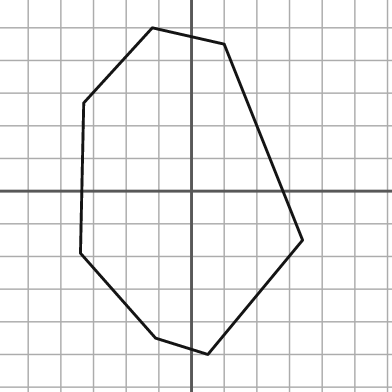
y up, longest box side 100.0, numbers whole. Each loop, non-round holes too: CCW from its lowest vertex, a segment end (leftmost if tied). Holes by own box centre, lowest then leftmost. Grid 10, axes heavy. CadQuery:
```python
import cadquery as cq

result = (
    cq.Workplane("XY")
    .moveTo(5.0, -50.0)
    .lineTo(34.0, -15.0)
    .lineTo(10.0, 45.0)
    .lineTo(-12.0, 50.0)
    .lineTo(-33.0, 27.0)
    .lineTo(-34.0, -19.0)
    .lineTo(-11.0, -45.0)
    .close()
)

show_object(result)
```